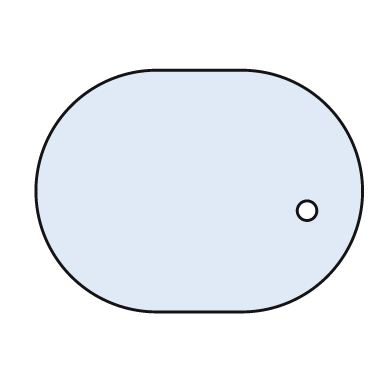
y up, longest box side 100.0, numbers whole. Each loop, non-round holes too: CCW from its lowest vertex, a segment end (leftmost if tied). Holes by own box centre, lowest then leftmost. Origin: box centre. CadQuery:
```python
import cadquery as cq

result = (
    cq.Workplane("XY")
    .moveTo(-13.0, -37.0)
    .lineTo(13.0, -37.0)
    .threePointArc((50.0, 0.0), (13.0, 37.0))
    .lineTo(-13.0, 37.0)
    .threePointArc((-50.0, 0.0), (-13.0, -37.0))
    .close()
    .moveTo(33.0, -6.0)
    .circle(3.0)
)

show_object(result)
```